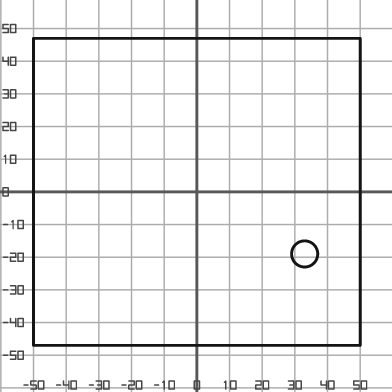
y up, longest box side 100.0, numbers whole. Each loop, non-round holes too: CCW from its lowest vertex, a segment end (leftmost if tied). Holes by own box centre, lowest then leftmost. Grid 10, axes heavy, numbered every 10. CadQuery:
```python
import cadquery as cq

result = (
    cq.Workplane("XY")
    .moveTo(-50.0, -47.0)
    .lineTo(50.0, -47.0)
    .lineTo(50.0, 47.0)
    .lineTo(-50.0, 47.0)
    .close()
    .moveTo(33.0, -19.0)
    .circle(4.0)
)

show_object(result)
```